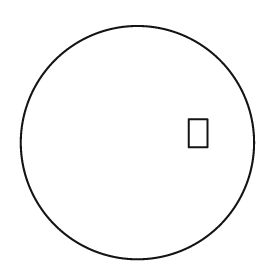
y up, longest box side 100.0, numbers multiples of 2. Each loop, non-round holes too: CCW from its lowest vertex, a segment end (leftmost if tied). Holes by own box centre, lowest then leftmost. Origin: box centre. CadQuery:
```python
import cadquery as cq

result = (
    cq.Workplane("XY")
    .moveTo(0.0, 0.0)
    .circle(50.0)
    .moveTo(22.0, -2.0)
    .lineTo(30.0, -2.0)
    .lineTo(30.0, 10.0)
    .lineTo(22.0, 10.0)
    .close()
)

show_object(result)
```